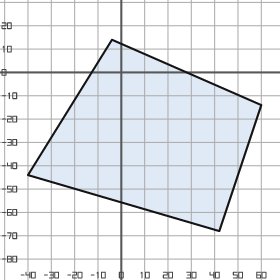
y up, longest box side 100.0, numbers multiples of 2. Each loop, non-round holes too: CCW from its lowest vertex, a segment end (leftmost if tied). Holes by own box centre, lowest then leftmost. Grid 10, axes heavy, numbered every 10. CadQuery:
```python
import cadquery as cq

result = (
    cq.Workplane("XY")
    .moveTo(42.0, -68.0)
    .lineTo(60.0, -14.0)
    .lineTo(-4.0, 14.0)
    .lineTo(-40.0, -44.0)
    .close()
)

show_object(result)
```